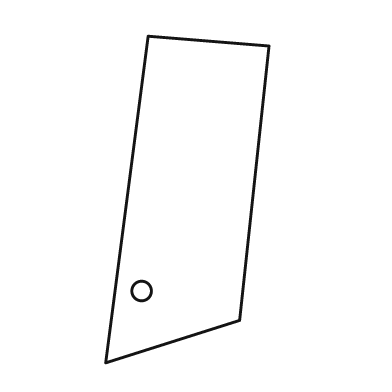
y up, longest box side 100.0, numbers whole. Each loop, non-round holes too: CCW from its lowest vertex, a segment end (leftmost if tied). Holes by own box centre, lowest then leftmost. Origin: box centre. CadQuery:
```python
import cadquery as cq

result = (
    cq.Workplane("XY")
    .moveTo(-25.0, -50.0)
    .lineTo(16.0, -37.0)
    .lineTo(25.0, 47.0)
    .lineTo(-12.0, 50.0)
    .close()
    .moveTo(-14.0, -28.0)
    .circle(3.0)
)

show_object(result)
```